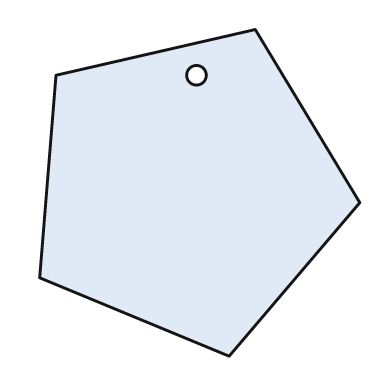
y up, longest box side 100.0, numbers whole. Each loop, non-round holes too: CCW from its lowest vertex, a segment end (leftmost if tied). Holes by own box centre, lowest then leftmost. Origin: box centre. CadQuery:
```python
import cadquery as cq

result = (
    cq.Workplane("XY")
    .moveTo(9.0, -50.0)
    .lineTo(49.0, -3.0)
    .lineTo(17.0, 50.0)
    .lineTo(-44.0, 36.0)
    .lineTo(-49.0, -26.0)
    .close()
    .moveTo(-1.0, 36.0)
    .circle(3.0)
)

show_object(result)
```